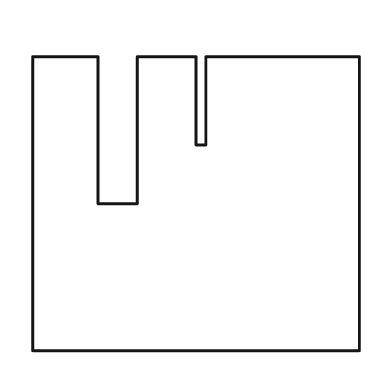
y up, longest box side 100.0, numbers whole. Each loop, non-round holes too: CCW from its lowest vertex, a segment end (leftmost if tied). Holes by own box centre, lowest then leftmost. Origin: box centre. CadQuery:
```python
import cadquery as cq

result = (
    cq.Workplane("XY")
    .moveTo(-50.0, -45.0)
    .lineTo(50.0, -45.0)
    .lineTo(50.0, 45.0)
    .lineTo(3.0, 45.0)
    .lineTo(3.0, 18.0)
    .lineTo(0.0, 18.0)
    .lineTo(0.0, 45.0)
    .lineTo(-18.0, 45.0)
    .lineTo(-18.0, 0.0)
    .lineTo(-30.0, 0.0)
    .lineTo(-30.0, 45.0)
    .lineTo(-50.0, 45.0)
    .close()
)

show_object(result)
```